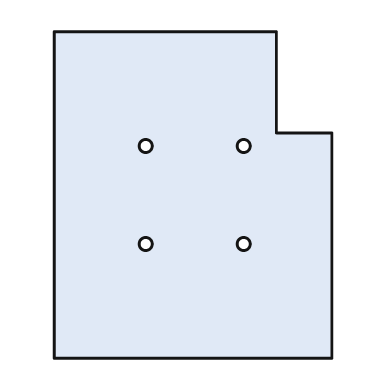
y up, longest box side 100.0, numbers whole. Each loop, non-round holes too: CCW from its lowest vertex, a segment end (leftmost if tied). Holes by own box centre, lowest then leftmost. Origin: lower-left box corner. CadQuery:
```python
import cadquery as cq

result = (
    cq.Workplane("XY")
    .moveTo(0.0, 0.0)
    .lineTo(85.0, 0.0)
    .lineTo(85.0, 69.0)
    .lineTo(68.0, 69.0)
    .lineTo(68.0, 100.0)
    .lineTo(0.0, 100.0)
    .close()
    .moveTo(28.0, 35.0)
    .circle(2.0)
    .moveTo(58.0, 35.0)
    .circle(2.0)
    .moveTo(28.0, 65.0)
    .circle(2.0)
    .moveTo(58.0, 65.0)
    .circle(2.0)
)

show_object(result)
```